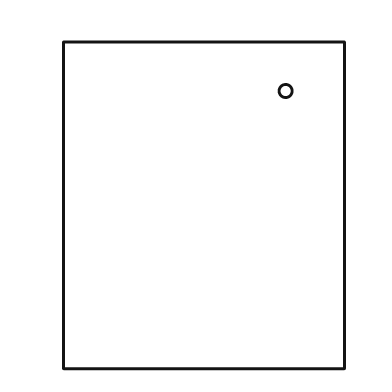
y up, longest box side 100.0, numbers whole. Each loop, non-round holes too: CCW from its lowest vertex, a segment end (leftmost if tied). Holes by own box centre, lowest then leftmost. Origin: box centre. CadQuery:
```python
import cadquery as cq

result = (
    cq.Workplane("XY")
    .moveTo(-43.0, -50.0)
    .lineTo(43.0, -50.0)
    .lineTo(43.0, 50.0)
    .lineTo(-43.0, 50.0)
    .close()
    .moveTo(25.0, 35.0)
    .circle(2.0)
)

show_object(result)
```